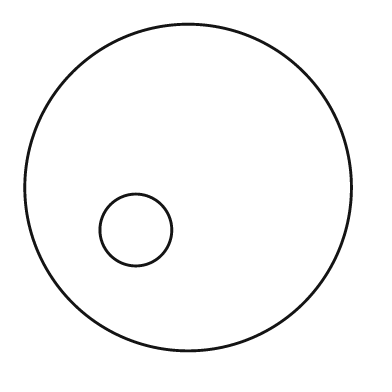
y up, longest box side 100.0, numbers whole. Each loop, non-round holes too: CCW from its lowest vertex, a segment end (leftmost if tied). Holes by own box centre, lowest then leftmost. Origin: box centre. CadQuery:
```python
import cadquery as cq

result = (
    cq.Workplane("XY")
    .moveTo(0.0, 0.0)
    .circle(50.0)
    .moveTo(-16.0, -13.0)
    .circle(11.0)
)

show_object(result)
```